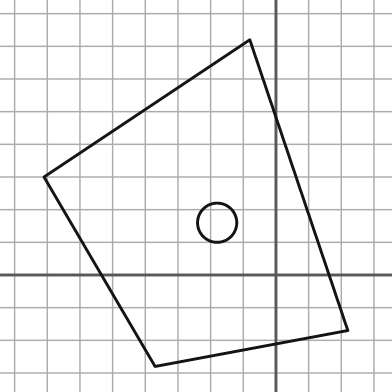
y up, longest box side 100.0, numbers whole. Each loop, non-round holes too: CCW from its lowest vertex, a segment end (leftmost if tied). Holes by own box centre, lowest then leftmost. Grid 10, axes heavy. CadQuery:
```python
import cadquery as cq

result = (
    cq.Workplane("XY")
    .moveTo(-37.0, -28.0)
    .lineTo(22.0, -17.0)
    .lineTo(-8.0, 72.0)
    .lineTo(-71.0, 30.0)
    .close()
    .moveTo(-18.0, 16.0)
    .circle(6.0)
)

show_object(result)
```